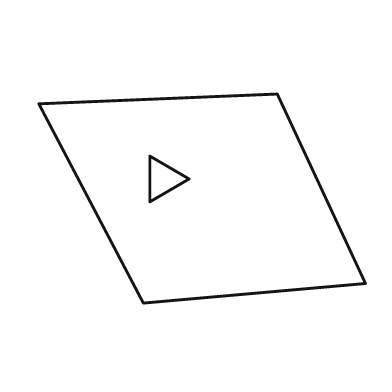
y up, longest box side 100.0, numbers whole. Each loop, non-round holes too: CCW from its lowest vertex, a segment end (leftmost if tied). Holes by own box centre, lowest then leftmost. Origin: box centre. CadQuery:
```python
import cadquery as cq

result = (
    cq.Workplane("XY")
    .moveTo(-18.0, -32.0)
    .lineTo(50.0, -26.0)
    .lineTo(23.0, 32.0)
    .lineTo(-50.0, 29.0)
    .close()
    .moveTo(-16.0, -1.0)
    .lineTo(-4.0, 6.0)
    .lineTo(-16.0, 13.0)
    .close()
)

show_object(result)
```